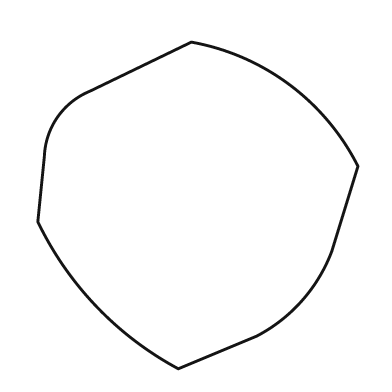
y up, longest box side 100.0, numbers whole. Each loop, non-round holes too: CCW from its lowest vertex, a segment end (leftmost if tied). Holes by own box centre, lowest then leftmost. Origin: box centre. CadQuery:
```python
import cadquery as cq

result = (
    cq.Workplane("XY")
    .moveTo(-6.0, -50.0)
    .lineTo(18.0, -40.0)
    .threePointArc((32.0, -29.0), (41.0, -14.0))
    .lineTo(49.0, 12.0)
    .threePointArc((28.0, 37.0), (-2.0, 50.0))
    .lineTo(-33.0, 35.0)
    .threePointArc((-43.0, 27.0), (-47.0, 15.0))
    .lineTo(-49.0, -5.0)
    .threePointArc((-31.0, -31.0), (-6.0, -50.0))
    .close()
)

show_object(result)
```